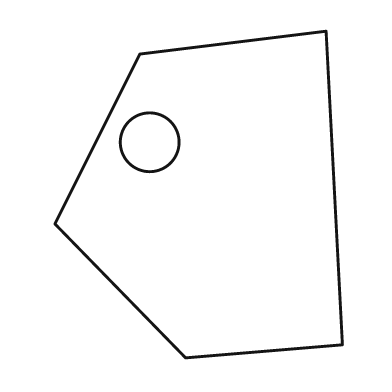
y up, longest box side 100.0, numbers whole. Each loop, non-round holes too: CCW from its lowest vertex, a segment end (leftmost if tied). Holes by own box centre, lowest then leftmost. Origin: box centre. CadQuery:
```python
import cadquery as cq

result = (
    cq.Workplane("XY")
    .moveTo(-4.0, -50.0)
    .lineTo(44.0, -46.0)
    .lineTo(39.0, 50.0)
    .lineTo(-18.0, 43.0)
    .lineTo(-44.0, -9.0)
    .close()
    .moveTo(-15.0, 16.0)
    .circle(9.0)
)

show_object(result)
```